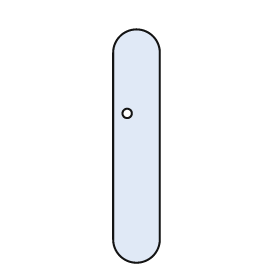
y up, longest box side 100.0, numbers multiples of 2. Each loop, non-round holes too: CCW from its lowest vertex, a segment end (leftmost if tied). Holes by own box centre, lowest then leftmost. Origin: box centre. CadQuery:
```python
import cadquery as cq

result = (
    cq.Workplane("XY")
    .moveTo(-10.0, -40.0)
    .threePointArc((0.0, -50.0), (10.0, -40.0))
    .lineTo(10.0, 40.0)
    .threePointArc((0.0, 50.0), (-10.0, 40.0))
    .close()
    .moveTo(-4.0, 14.0)
    .circle(2.0)
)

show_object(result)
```